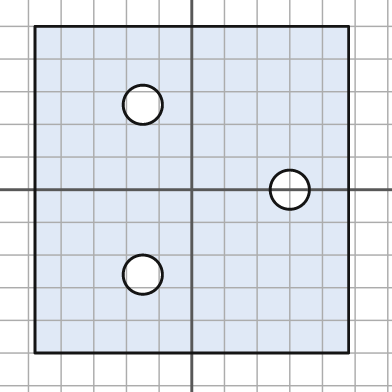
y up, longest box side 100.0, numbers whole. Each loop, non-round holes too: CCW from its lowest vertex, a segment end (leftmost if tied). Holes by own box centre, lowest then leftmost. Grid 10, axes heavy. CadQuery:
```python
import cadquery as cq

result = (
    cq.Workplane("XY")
    .moveTo(-48.0, -50.0)
    .lineTo(48.0, -50.0)
    .lineTo(48.0, 50.0)
    .lineTo(-48.0, 50.0)
    .close()
    .moveTo(-15.0, -26.0)
    .circle(6.0)
    .moveTo(30.0, 0.0)
    .circle(6.0)
    .moveTo(-15.0, 26.0)
    .circle(6.0)
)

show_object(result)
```